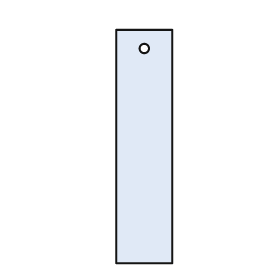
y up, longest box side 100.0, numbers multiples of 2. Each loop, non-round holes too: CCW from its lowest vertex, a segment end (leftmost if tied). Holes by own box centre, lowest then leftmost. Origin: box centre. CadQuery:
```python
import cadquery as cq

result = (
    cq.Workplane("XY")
    .moveTo(-12.0, -50.0)
    .lineTo(12.0, -50.0)
    .lineTo(12.0, 50.0)
    .lineTo(-12.0, 50.0)
    .close()
    .moveTo(0.0, 42.0)
    .circle(2.0)
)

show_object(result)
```